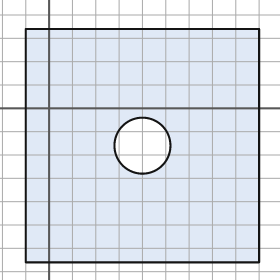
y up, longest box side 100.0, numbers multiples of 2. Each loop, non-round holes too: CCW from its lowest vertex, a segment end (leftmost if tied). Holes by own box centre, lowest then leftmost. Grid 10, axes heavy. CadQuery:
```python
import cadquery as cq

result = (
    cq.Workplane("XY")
    .moveTo(-10.0, -66.0)
    .lineTo(90.0, -66.0)
    .lineTo(90.0, 34.0)
    .lineTo(-10.0, 34.0)
    .close()
    .moveTo(40.0, -16.0)
    .circle(12.0)
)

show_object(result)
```